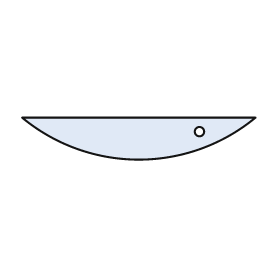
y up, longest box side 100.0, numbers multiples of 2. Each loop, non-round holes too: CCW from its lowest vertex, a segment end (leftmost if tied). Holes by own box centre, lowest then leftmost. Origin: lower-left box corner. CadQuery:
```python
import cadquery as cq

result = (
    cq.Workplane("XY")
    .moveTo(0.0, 18.0)
    .threePointArc((50.0, 0.0), (100.0, 18.0))
    .close()
    .moveTo(76.0, 12.0)
    .circle(2.0)
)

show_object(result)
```